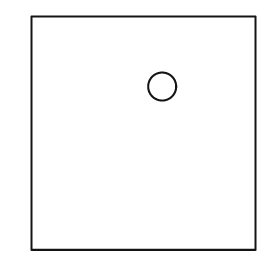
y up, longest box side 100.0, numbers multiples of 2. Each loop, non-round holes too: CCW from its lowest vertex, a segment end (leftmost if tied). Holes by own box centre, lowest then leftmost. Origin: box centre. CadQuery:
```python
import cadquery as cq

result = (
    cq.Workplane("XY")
    .moveTo(-48.0, -50.0)
    .lineTo(48.0, -50.0)
    .lineTo(48.0, 50.0)
    .lineTo(-48.0, 50.0)
    .close()
    .moveTo(8.0, 20.0)
    .circle(6.0)
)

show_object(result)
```